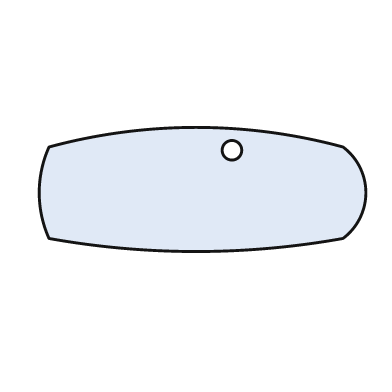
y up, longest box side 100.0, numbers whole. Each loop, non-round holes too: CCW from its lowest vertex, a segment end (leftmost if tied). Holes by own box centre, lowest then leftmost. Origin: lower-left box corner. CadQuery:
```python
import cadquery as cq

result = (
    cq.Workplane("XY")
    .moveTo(3.0, 4.0)
    .threePointArc((48.0, 0.0), (93.0, 4.0))
    .threePointArc((100.0, 18.0), (93.0, 32.0))
    .threePointArc((48.0, 38.0), (3.0, 32.0))
    .threePointArc((0.0, 18.0), (3.0, 4.0))
    .close()
    .moveTo(59.0, 31.0)
    .circle(3.0)
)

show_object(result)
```